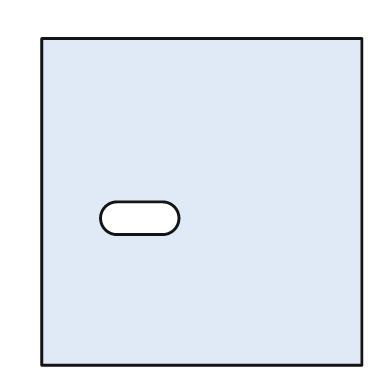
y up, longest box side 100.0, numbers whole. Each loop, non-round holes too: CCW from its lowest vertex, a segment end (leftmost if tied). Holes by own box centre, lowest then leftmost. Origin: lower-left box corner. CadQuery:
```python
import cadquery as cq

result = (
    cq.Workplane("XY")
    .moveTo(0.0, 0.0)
    .lineTo(98.0, 0.0)
    .lineTo(98.0, 100.0)
    .lineTo(0.0, 100.0)
    .close()
    .moveTo(23.0, 40.0)
    .lineTo(37.0, 40.0)
    .threePointArc((42.0, 45.0), (37.0, 50.0))
    .lineTo(23.0, 50.0)
    .threePointArc((18.0, 45.0), (23.0, 40.0))
    .close()
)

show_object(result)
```